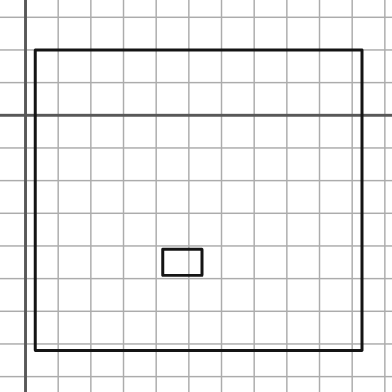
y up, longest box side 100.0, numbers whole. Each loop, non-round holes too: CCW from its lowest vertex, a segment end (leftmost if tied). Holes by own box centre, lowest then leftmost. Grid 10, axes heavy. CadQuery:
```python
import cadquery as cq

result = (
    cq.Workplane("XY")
    .moveTo(3.0, -72.0)
    .lineTo(103.0, -72.0)
    .lineTo(103.0, 20.0)
    .lineTo(3.0, 20.0)
    .close()
    .moveTo(42.0, -49.0)
    .lineTo(54.0, -49.0)
    .lineTo(54.0, -41.0)
    .lineTo(42.0, -41.0)
    .close()
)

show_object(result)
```